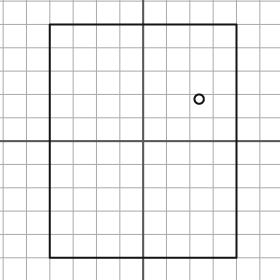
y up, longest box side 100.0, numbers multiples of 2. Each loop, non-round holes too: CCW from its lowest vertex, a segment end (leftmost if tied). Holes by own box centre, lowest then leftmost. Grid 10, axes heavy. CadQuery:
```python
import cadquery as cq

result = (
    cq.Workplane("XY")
    .moveTo(-40.0, -50.0)
    .lineTo(40.0, -50.0)
    .lineTo(40.0, 50.0)
    .lineTo(-40.0, 50.0)
    .close()
    .moveTo(24.0, 18.0)
    .circle(2.0)
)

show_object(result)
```